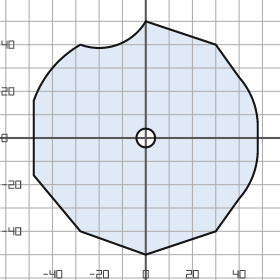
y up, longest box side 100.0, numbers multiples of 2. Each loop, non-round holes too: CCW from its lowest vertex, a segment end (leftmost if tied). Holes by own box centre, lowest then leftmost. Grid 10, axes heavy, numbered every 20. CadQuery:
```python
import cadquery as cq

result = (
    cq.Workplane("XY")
    .moveTo(0.0, -50.0)
    .lineTo(30.0, -40.0)
    .lineTo(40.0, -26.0)
    .threePointArc((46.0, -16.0), (48.0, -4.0))
    .lineTo(48.0, 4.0)
    .threePointArc((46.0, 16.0), (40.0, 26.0))
    .lineTo(30.0, 40.0)
    .lineTo(0.0, 50.0)
    .threePointArc((-12.0, 40.0), (-28.0, 40.0))
    .threePointArc((-40.0, 30.0), (-48.0, 16.0))
    .lineTo(-48.0, -16.0)
    .lineTo(-28.0, -40.0)
    .close()
    .moveTo(0.0, 0.0)
    .circle(4.0)
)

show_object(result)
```